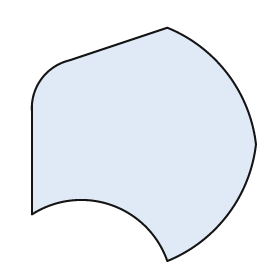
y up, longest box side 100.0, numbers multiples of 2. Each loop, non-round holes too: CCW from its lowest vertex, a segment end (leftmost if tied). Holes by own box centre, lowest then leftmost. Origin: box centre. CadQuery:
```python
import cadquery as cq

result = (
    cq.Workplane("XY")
    .moveTo(10.0, -50.0)
    .threePointArc((36.0, -30.0), (48.0, 0.0))
    .threePointArc((36.0, 30.0), (10.0, 50.0))
    .lineTo(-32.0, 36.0)
    .threePointArc((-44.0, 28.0), (-48.0, 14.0))
    .lineTo(-48.0, -30.0)
    .threePointArc((-14.0, -26.0), (10.0, -50.0))
    .close()
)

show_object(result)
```